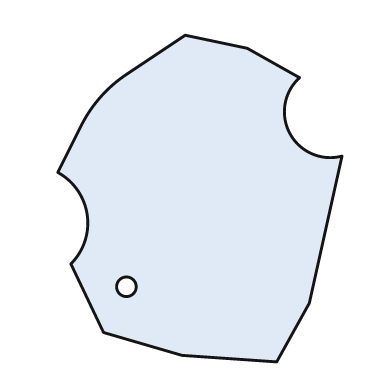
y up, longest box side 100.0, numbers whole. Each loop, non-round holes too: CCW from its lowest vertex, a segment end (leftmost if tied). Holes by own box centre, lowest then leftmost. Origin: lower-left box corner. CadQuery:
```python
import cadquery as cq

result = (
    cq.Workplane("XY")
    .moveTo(67.0, 0.0)
    .lineTo(77.0, 18.0)
    .lineTo(87.0, 63.0)
    .threePointArc((71.0, 70.0), (74.0, 87.0))
    .lineTo(58.0, 96.0)
    .lineTo(39.0, 100.0)
    .lineTo(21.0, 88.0)
    .threePointArc((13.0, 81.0), (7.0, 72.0))
    .lineTo(0.0, 58.0)
    .threePointArc((9.0, 45.0), (4.0, 30.0))
    .lineTo(14.0, 9.0)
    .lineTo(38.0, 2.0)
    .close()
    .moveTo(21.0, 23.0)
    .circle(3.0)
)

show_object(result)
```